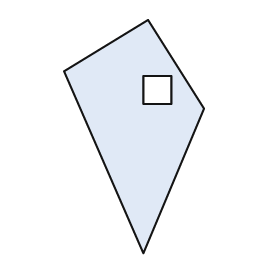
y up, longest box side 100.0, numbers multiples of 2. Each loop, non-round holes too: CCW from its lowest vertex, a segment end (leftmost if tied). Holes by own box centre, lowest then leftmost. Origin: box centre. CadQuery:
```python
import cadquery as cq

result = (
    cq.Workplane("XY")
    .moveTo(4.0, -50.0)
    .lineTo(30.0, 12.0)
    .lineTo(6.0, 50.0)
    .lineTo(-30.0, 28.0)
    .close()
    .moveTo(4.0, 14.0)
    .lineTo(16.0, 14.0)
    .lineTo(16.0, 26.0)
    .lineTo(4.0, 26.0)
    .close()
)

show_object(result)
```